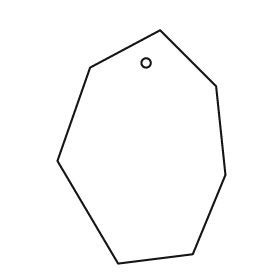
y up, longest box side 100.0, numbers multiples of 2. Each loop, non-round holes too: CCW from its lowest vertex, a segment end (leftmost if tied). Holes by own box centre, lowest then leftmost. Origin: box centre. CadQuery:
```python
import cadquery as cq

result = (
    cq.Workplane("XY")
    .moveTo(-10.0, -50.0)
    .lineTo(22.0, -46.0)
    .lineTo(36.0, -12.0)
    .lineTo(32.0, 26.0)
    .lineTo(8.0, 50.0)
    .lineTo(-22.0, 34.0)
    .lineTo(-36.0, -6.0)
    .close()
    .moveTo(2.0, 36.0)
    .circle(2.0)
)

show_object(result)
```